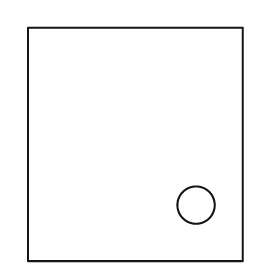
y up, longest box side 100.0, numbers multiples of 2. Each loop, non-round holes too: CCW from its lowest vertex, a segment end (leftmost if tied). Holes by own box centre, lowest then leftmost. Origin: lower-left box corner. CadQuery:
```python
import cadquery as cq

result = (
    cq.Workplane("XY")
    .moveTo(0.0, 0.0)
    .lineTo(92.0, 0.0)
    .lineTo(92.0, 100.0)
    .lineTo(0.0, 100.0)
    .close()
    .moveTo(72.0, 24.0)
    .circle(8.0)
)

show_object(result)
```